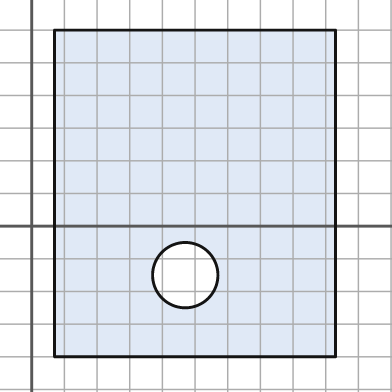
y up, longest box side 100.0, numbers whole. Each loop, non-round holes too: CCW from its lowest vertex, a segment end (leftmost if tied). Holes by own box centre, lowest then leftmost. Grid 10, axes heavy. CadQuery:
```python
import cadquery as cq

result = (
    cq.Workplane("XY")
    .moveTo(7.0, -40.0)
    .lineTo(93.0, -40.0)
    .lineTo(93.0, 60.0)
    .lineTo(7.0, 60.0)
    .close()
    .moveTo(47.0, -15.0)
    .circle(10.0)
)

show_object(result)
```